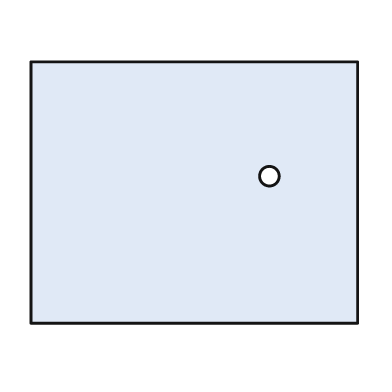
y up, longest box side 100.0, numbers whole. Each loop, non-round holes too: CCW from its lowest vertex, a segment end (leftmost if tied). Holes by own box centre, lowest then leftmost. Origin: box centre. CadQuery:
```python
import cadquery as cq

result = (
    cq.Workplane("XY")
    .moveTo(-50.0, -40.0)
    .lineTo(50.0, -40.0)
    .lineTo(50.0, 40.0)
    .lineTo(-50.0, 40.0)
    .close()
    .moveTo(23.0, 5.0)
    .circle(3.0)
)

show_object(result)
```